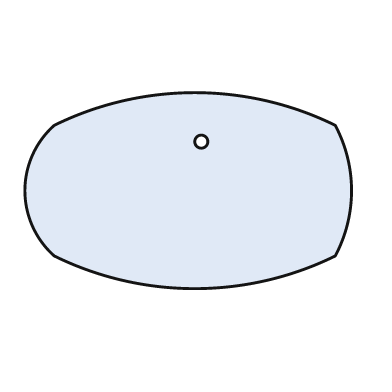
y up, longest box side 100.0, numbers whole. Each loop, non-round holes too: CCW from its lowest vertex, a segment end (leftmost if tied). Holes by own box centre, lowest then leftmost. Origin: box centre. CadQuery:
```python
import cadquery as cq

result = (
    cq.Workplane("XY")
    .moveTo(-41.0, -20.0)
    .threePointArc((2.0, -30.0), (45.0, -20.0))
    .threePointArc((50.0, 0.0), (45.0, 20.0))
    .threePointArc((2.0, 30.0), (-41.0, 20.0))
    .threePointArc((-50.0, 0.0), (-41.0, -20.0))
    .close()
    .moveTo(4.0, 15.0)
    .circle(2.0)
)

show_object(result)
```